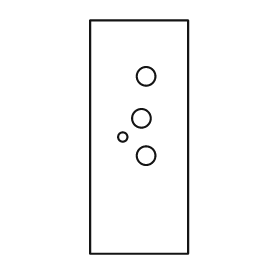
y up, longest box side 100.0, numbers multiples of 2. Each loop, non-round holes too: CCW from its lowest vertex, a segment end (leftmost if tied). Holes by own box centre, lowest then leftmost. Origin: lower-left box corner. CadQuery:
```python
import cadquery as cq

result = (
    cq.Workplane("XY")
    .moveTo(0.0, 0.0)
    .lineTo(42.0, 0.0)
    .lineTo(42.0, 100.0)
    .lineTo(0.0, 100.0)
    .close()
    .moveTo(24.0, 42.0)
    .circle(4.0)
    .moveTo(14.0, 50.0)
    .circle(2.0)
    .moveTo(22.0, 58.0)
    .circle(4.0)
    .moveTo(24.0, 76.0)
    .circle(4.0)
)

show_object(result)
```